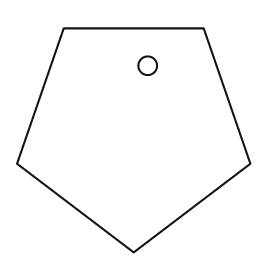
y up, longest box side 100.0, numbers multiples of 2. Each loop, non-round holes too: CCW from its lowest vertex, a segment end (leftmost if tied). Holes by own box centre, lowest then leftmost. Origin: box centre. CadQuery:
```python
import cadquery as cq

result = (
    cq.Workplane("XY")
    .moveTo(0.0, -48.0)
    .lineTo(50.0, -10.0)
    .lineTo(30.0, 48.0)
    .lineTo(-30.0, 48.0)
    .lineTo(-50.0, -10.0)
    .close()
    .moveTo(6.0, 32.0)
    .circle(4.0)
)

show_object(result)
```